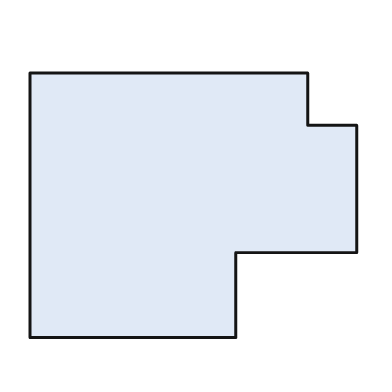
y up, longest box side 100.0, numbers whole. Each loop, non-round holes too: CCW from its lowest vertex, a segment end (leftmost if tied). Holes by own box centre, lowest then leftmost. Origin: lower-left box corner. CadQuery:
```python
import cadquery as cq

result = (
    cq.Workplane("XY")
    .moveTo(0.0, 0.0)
    .lineTo(63.0, 0.0)
    .lineTo(63.0, 26.0)
    .lineTo(100.0, 26.0)
    .lineTo(100.0, 65.0)
    .lineTo(85.0, 65.0)
    .lineTo(85.0, 81.0)
    .lineTo(0.0, 81.0)
    .close()
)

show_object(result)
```